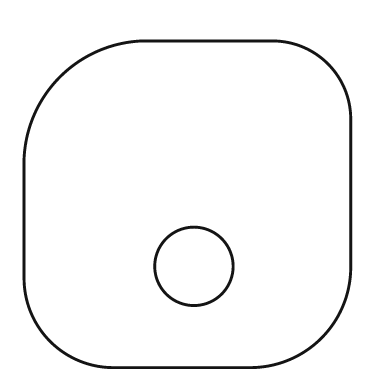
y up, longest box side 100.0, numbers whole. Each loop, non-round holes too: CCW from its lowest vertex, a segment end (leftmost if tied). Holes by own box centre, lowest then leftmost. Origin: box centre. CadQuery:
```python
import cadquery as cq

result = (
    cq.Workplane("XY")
    .moveTo(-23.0, -50.0)
    .lineTo(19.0, -50.0)
    .threePointArc((41.0, -41.0), (50.0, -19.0))
    .lineTo(50.0, 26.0)
    .threePointArc((43.0, 43.0), (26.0, 50.0))
    .lineTo(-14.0, 50.0)
    .threePointArc((-39.0, 39.0), (-50.0, 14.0))
    .lineTo(-50.0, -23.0)
    .threePointArc((-42.0, -42.0), (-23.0, -50.0))
    .close()
    .moveTo(2.0, -19.0)
    .circle(12.0)
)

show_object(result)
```